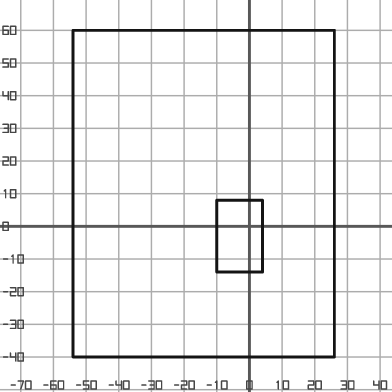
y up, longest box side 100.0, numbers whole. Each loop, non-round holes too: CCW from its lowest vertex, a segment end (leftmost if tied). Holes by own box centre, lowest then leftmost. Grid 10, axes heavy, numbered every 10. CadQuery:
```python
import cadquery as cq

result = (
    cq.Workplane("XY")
    .moveTo(-54.0, -40.0)
    .lineTo(26.0, -40.0)
    .lineTo(26.0, 60.0)
    .lineTo(-54.0, 60.0)
    .close()
    .moveTo(-10.0, -14.0)
    .lineTo(4.0, -14.0)
    .lineTo(4.0, 8.0)
    .lineTo(-10.0, 8.0)
    .close()
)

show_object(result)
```